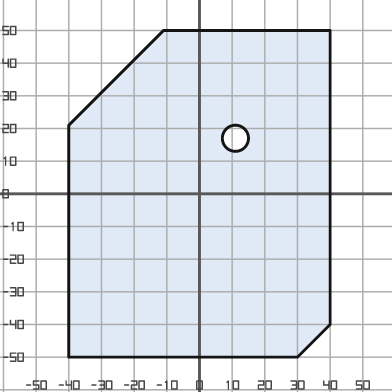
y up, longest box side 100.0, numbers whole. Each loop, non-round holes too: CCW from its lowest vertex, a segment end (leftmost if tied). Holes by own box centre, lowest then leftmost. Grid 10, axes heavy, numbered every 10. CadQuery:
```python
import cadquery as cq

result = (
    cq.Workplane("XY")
    .moveTo(-40.0, -50.0)
    .lineTo(30.0, -50.0)
    .lineTo(40.0, -40.0)
    .lineTo(40.0, 50.0)
    .lineTo(-11.0, 50.0)
    .lineTo(-40.0, 21.0)
    .close()
    .moveTo(11.0, 17.0)
    .circle(4.0)
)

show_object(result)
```